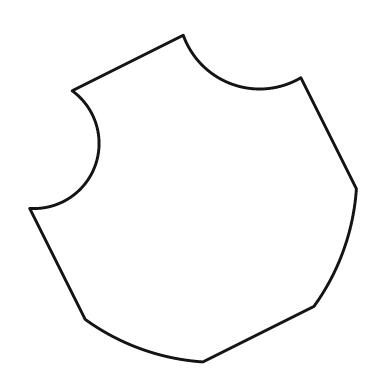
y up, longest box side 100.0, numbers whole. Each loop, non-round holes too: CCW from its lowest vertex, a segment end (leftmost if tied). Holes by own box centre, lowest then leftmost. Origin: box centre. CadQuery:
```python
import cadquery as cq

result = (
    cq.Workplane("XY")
    .moveTo(3.0, -50.0)
    .lineTo(37.0, -33.0)
    .threePointArc((46.0, -16.0), (50.0, 3.0))
    .lineTo(33.0, 37.0)
    .threePointArc((12.0, 35.0), (-3.0, 50.0))
    .lineTo(-37.0, 33.0)
    .threePointArc((-30.0, 10.0), (-50.0, -3.0))
    .lineTo(-33.0, -37.0)
    .threePointArc((-16.0, -46.0), (3.0, -50.0))
    .close()
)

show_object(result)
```